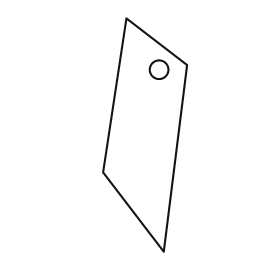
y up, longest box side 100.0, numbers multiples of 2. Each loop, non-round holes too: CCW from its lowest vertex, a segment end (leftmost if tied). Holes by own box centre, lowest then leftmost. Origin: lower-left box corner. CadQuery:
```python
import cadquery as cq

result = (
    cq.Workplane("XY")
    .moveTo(26.0, 0.0)
    .lineTo(36.0, 80.0)
    .lineTo(10.0, 100.0)
    .lineTo(0.0, 34.0)
    .close()
    .moveTo(24.0, 78.0)
    .circle(4.0)
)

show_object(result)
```